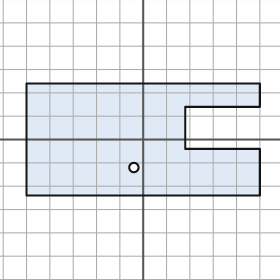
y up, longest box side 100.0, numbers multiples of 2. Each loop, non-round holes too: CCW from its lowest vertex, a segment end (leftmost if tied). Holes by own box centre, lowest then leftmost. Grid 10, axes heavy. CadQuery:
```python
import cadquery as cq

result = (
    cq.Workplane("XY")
    .moveTo(-50.0, -24.0)
    .lineTo(50.0, -24.0)
    .lineTo(50.0, -4.0)
    .lineTo(18.0, -4.0)
    .lineTo(18.0, 14.0)
    .lineTo(50.0, 14.0)
    .lineTo(50.0, 24.0)
    .lineTo(-50.0, 24.0)
    .close()
    .moveTo(-4.0, -12.0)
    .circle(2.0)
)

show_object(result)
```